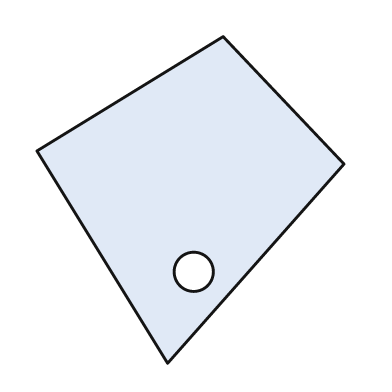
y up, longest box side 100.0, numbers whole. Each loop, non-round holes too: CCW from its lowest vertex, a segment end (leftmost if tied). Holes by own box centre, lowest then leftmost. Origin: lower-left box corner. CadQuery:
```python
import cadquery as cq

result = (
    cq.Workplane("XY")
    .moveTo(40.0, 0.0)
    .lineTo(94.0, 61.0)
    .lineTo(57.0, 100.0)
    .lineTo(0.0, 65.0)
    .close()
    .moveTo(48.0, 28.0)
    .circle(6.0)
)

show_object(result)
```